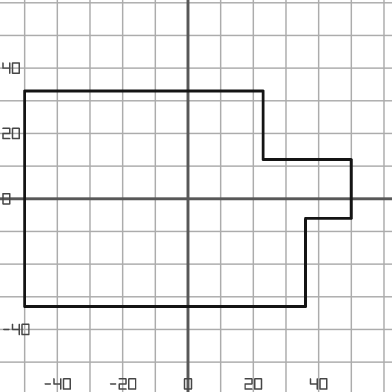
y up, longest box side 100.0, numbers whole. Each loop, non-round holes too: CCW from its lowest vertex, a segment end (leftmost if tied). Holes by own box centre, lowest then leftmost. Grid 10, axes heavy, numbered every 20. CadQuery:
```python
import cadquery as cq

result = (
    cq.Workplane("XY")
    .moveTo(-50.0, -33.0)
    .lineTo(36.0, -33.0)
    .lineTo(36.0, -6.0)
    .lineTo(50.0, -6.0)
    .lineTo(50.0, 12.0)
    .lineTo(23.0, 12.0)
    .lineTo(23.0, 33.0)
    .lineTo(-50.0, 33.0)
    .close()
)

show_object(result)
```